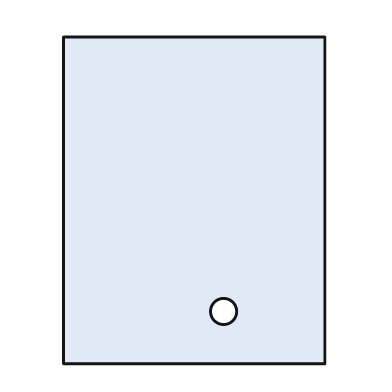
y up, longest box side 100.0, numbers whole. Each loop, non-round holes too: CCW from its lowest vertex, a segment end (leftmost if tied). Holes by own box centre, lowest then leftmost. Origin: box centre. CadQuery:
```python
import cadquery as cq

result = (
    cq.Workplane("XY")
    .moveTo(-40.0, -50.0)
    .lineTo(40.0, -50.0)
    .lineTo(40.0, 50.0)
    .lineTo(-40.0, 50.0)
    .close()
    .moveTo(9.0, -34.0)
    .circle(4.0)
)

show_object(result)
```